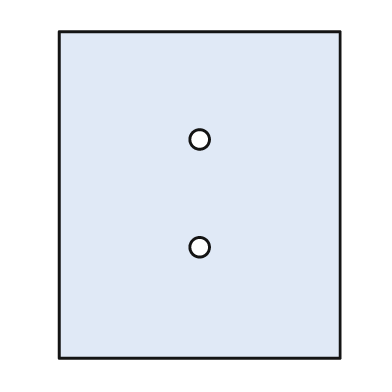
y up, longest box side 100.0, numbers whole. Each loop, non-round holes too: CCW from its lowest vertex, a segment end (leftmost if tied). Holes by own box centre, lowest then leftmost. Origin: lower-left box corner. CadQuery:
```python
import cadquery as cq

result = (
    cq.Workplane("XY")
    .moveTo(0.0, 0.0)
    .lineTo(86.0, 0.0)
    .lineTo(86.0, 100.0)
    .lineTo(0.0, 100.0)
    .close()
    .moveTo(43.0, 34.0)
    .circle(3.0)
    .moveTo(43.0, 67.0)
    .circle(3.0)
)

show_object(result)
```